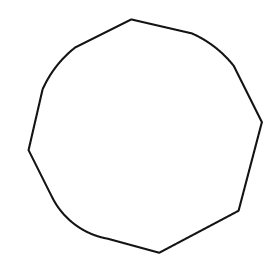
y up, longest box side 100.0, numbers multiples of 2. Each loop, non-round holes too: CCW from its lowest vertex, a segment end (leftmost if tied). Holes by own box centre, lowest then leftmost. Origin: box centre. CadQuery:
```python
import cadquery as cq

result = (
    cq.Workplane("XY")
    .moveTo(6.0, -50.0)
    .lineTo(40.0, -32.0)
    .lineTo(50.0, 6.0)
    .lineTo(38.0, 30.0)
    .threePointArc((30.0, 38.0), (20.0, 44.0))
    .lineTo(-6.0, 50.0)
    .lineTo(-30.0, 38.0)
    .threePointArc((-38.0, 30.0), (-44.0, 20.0))
    .lineTo(-50.0, -6.0)
    .lineTo(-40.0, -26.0)
    .threePointArc((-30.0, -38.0), (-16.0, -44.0))
    .close()
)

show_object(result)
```